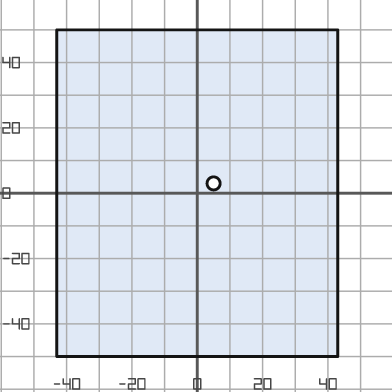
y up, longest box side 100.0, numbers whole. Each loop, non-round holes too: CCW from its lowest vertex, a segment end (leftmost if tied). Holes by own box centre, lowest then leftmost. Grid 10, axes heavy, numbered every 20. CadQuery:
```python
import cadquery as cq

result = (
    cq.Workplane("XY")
    .moveTo(-43.0, -50.0)
    .lineTo(43.0, -50.0)
    .lineTo(43.0, 50.0)
    .lineTo(-43.0, 50.0)
    .close()
    .moveTo(5.0, 3.0)
    .circle(2.0)
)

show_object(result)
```